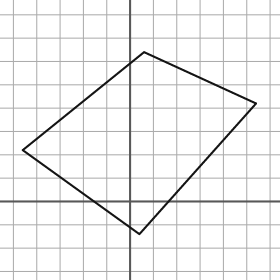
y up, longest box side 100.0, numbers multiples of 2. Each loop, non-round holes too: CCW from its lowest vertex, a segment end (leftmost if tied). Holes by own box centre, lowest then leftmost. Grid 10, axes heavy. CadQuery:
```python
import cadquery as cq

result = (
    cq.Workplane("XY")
    .moveTo(4.0, -14.0)
    .lineTo(54.0, 42.0)
    .lineTo(6.0, 64.0)
    .lineTo(-46.0, 22.0)
    .close()
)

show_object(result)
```